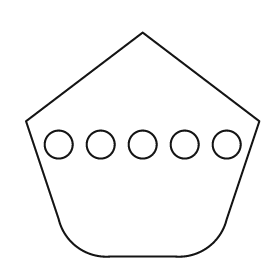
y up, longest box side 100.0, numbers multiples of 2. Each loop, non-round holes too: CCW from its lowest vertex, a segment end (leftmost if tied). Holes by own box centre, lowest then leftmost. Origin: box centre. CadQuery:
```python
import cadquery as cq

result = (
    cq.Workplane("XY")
    .moveTo(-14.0, -48.0)
    .lineTo(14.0, -48.0)
    .threePointArc((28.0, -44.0), (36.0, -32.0))
    .lineTo(50.0, 10.0)
    .lineTo(0.0, 48.0)
    .lineTo(-50.0, 10.0)
    .lineTo(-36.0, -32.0)
    .threePointArc((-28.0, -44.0), (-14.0, -48.0))
    .close()
    .moveTo(-36.0, 0.0)
    .circle(6.0)
    .moveTo(-18.0, 0.0)
    .circle(6.0)
    .moveTo(0.0, 0.0)
    .circle(6.0)
    .moveTo(18.0, 0.0)
    .circle(6.0)
    .moveTo(36.0, 0.0)
    .circle(6.0)
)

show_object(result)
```